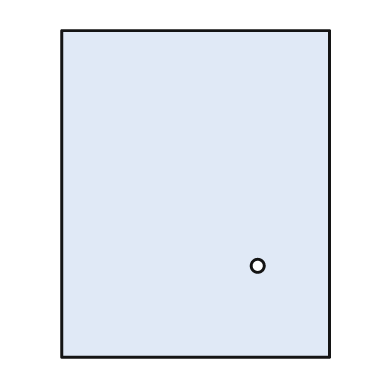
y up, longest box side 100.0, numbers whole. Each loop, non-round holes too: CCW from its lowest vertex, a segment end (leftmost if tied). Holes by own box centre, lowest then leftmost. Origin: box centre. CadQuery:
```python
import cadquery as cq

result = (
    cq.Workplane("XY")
    .moveTo(-41.0, -50.0)
    .lineTo(41.0, -50.0)
    .lineTo(41.0, 50.0)
    .lineTo(-41.0, 50.0)
    .close()
    .moveTo(19.0, -22.0)
    .circle(2.0)
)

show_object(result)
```